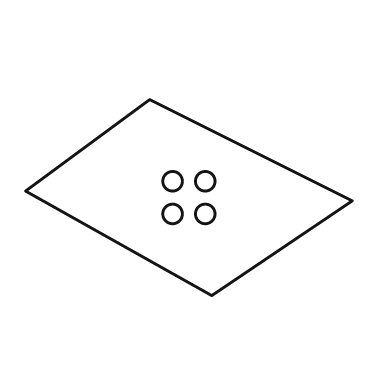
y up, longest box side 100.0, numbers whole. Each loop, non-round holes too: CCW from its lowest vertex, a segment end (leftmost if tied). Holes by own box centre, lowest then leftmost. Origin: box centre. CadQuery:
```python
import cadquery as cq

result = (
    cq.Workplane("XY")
    .moveTo(7.0, -30.0)
    .lineTo(50.0, -1.0)
    .lineTo(-12.0, 30.0)
    .lineTo(-50.0, 2.0)
    .close()
    .moveTo(-5.0, -5.0)
    .circle(3.0)
    .moveTo(5.0, -5.0)
    .circle(3.0)
    .moveTo(-5.0, 5.0)
    .circle(3.0)
    .moveTo(5.0, 5.0)
    .circle(3.0)
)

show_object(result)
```